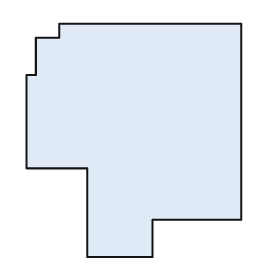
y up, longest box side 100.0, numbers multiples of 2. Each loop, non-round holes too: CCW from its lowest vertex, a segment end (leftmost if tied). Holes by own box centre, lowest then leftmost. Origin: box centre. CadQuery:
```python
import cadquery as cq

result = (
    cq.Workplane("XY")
    .moveTo(-20.0, -50.0)
    .lineTo(8.0, -50.0)
    .lineTo(8.0, -34.0)
    .lineTo(46.0, -34.0)
    .lineTo(46.0, 50.0)
    .lineTo(-32.0, 50.0)
    .lineTo(-32.0, 44.0)
    .lineTo(-42.0, 44.0)
    .lineTo(-42.0, 28.0)
    .lineTo(-46.0, 28.0)
    .lineTo(-46.0, -12.0)
    .lineTo(-20.0, -12.0)
    .close()
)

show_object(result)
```